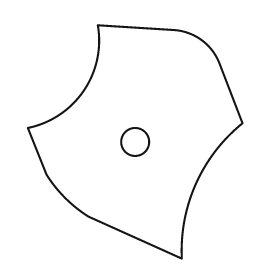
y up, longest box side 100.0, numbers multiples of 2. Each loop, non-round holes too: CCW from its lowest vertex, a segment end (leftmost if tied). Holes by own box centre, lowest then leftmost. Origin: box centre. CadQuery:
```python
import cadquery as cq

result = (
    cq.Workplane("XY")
    .moveTo(20.0, -50.0)
    .threePointArc((26.0, -18.0), (46.0, 8.0))
    .lineTo(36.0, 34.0)
    .threePointArc((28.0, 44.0), (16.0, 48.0))
    .lineTo(-16.0, 50.0)
    .threePointArc((-22.0, 22.0), (-46.0, 6.0))
    .lineTo(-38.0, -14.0)
    .threePointArc((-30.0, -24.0), (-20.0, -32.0))
    .close()
    .moveTo(0.0, 0.0)
    .circle(6.0)
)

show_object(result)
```